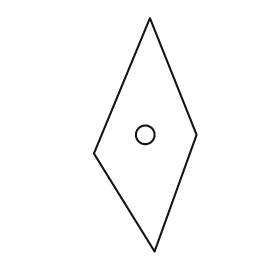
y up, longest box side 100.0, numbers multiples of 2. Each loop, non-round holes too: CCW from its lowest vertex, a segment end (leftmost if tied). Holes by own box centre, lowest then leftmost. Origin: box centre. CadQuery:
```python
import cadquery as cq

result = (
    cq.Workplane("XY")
    .moveTo(4.0, -50.0)
    .lineTo(22.0, 0.0)
    .lineTo(2.0, 50.0)
    .lineTo(-22.0, -8.0)
    .close()
    .moveTo(0.0, 0.0)
    .circle(4.0)
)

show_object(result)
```